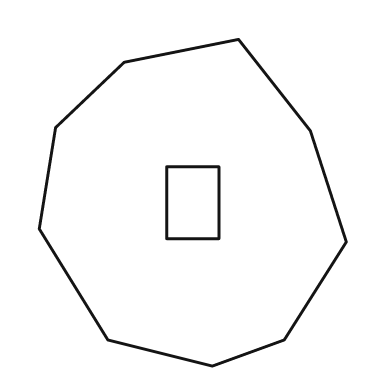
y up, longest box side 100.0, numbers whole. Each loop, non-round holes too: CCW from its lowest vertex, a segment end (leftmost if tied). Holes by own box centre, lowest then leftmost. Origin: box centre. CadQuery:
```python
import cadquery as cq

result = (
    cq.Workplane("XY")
    .moveTo(6.0, -50.0)
    .lineTo(28.0, -42.0)
    .lineTo(47.0, -12.0)
    .lineTo(36.0, 22.0)
    .lineTo(14.0, 50.0)
    .lineTo(-21.0, 43.0)
    .lineTo(-42.0, 23.0)
    .lineTo(-47.0, -8.0)
    .lineTo(-26.0, -42.0)
    .close()
    .moveTo(-8.0, -11.0)
    .lineTo(8.0, -11.0)
    .lineTo(8.0, 11.0)
    .lineTo(-8.0, 11.0)
    .close()
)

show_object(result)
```